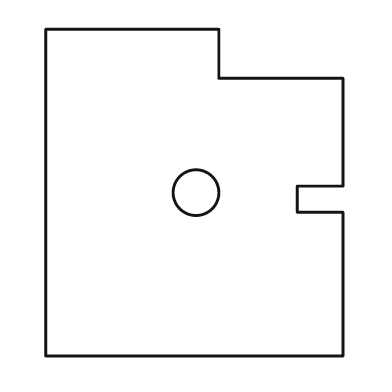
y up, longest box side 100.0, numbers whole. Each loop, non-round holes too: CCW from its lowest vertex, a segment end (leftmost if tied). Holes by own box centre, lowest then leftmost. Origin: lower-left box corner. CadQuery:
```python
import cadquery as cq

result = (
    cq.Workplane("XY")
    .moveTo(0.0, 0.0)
    .lineTo(91.0, 0.0)
    .lineTo(91.0, 44.0)
    .lineTo(77.0, 44.0)
    .lineTo(77.0, 52.0)
    .lineTo(91.0, 52.0)
    .lineTo(91.0, 85.0)
    .lineTo(53.0, 85.0)
    .lineTo(53.0, 100.0)
    .lineTo(0.0, 100.0)
    .close()
    .moveTo(46.0, 50.0)
    .circle(7.0)
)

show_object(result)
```